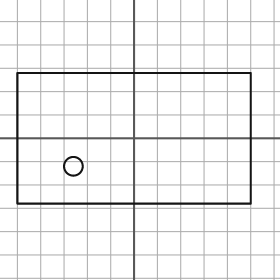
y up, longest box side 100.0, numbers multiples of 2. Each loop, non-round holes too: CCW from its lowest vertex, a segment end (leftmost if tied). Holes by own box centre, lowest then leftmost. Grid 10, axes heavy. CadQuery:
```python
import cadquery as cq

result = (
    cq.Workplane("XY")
    .moveTo(-50.0, -28.0)
    .lineTo(50.0, -28.0)
    .lineTo(50.0, 28.0)
    .lineTo(-50.0, 28.0)
    .close()
    .moveTo(-26.0, -12.0)
    .circle(4.0)
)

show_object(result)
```